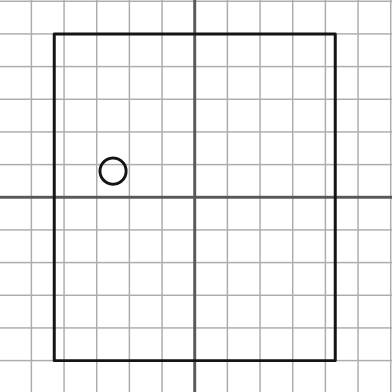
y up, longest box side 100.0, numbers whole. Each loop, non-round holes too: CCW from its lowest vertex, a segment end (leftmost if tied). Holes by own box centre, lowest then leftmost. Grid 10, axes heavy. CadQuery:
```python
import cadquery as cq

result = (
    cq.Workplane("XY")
    .moveTo(-43.0, -50.0)
    .lineTo(43.0, -50.0)
    .lineTo(43.0, 50.0)
    .lineTo(-43.0, 50.0)
    .close()
    .moveTo(-25.0, 8.0)
    .circle(4.0)
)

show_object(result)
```